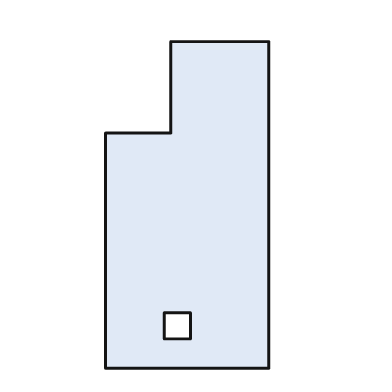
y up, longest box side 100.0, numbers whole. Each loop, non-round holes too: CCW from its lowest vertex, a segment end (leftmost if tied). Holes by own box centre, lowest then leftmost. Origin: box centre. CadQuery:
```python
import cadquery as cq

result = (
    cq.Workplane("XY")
    .moveTo(-25.0, -50.0)
    .lineTo(25.0, -50.0)
    .lineTo(25.0, 50.0)
    .lineTo(-5.0, 50.0)
    .lineTo(-5.0, 22.0)
    .lineTo(-25.0, 22.0)
    .close()
    .moveTo(-7.0, -41.0)
    .lineTo(1.0, -41.0)
    .lineTo(1.0, -33.0)
    .lineTo(-7.0, -33.0)
    .close()
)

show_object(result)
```